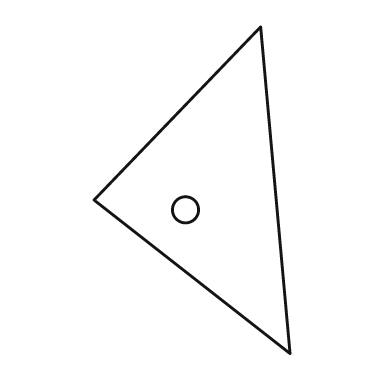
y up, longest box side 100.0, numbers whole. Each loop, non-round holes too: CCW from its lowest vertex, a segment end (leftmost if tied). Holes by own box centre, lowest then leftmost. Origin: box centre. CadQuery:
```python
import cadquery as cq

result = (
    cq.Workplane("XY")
    .moveTo(30.0, -50.0)
    .lineTo(21.0, 50.0)
    .lineTo(-30.0, -3.0)
    .close()
    .moveTo(-2.0, -6.0)
    .circle(4.0)
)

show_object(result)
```